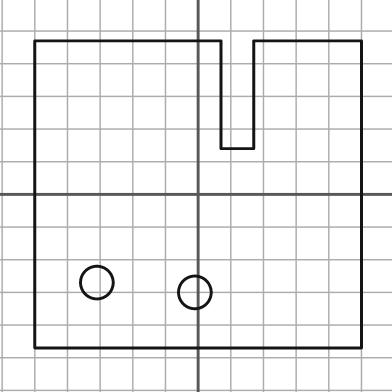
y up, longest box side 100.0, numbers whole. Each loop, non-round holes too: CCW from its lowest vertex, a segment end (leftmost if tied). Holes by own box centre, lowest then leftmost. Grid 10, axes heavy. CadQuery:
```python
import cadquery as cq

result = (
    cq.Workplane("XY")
    .moveTo(-50.0, -47.0)
    .lineTo(50.0, -47.0)
    .lineTo(50.0, 47.0)
    .lineTo(17.0, 47.0)
    .lineTo(17.0, 14.0)
    .lineTo(7.0, 14.0)
    .lineTo(7.0, 47.0)
    .lineTo(-50.0, 47.0)
    .close()
    .moveTo(-1.0, -30.0)
    .circle(5.0)
    .moveTo(-31.0, -27.0)
    .circle(5.0)
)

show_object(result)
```